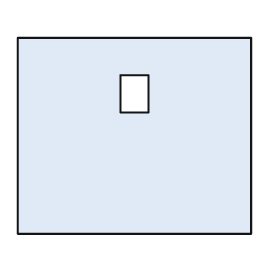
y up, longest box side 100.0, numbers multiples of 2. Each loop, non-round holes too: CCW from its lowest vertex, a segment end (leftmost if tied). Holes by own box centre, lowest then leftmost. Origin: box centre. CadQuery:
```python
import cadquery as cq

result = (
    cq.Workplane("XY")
    .moveTo(-50.0, -42.0)
    .lineTo(50.0, -42.0)
    .lineTo(50.0, 42.0)
    .lineTo(-50.0, 42.0)
    .close()
    .moveTo(-6.0, 10.0)
    .lineTo(6.0, 10.0)
    .lineTo(6.0, 26.0)
    .lineTo(-6.0, 26.0)
    .close()
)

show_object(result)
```